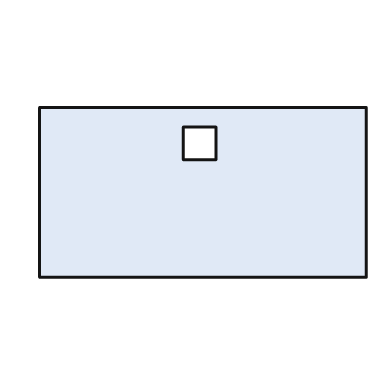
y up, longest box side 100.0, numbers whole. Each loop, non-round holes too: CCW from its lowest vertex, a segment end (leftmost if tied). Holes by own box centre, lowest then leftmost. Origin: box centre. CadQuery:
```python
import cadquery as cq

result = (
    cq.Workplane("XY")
    .moveTo(-50.0, -26.0)
    .lineTo(50.0, -26.0)
    .lineTo(50.0, 26.0)
    .lineTo(-50.0, 26.0)
    .close()
    .moveTo(-6.0, 10.0)
    .lineTo(4.0, 10.0)
    .lineTo(4.0, 20.0)
    .lineTo(-6.0, 20.0)
    .close()
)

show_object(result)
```